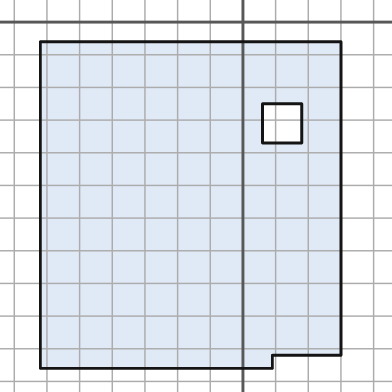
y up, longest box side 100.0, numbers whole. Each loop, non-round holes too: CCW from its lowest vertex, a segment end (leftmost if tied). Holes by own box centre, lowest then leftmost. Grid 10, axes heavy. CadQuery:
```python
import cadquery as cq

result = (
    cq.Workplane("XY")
    .moveTo(-62.0, -106.0)
    .lineTo(9.0, -106.0)
    .lineTo(9.0, -102.0)
    .lineTo(30.0, -102.0)
    .lineTo(30.0, -6.0)
    .lineTo(-62.0, -6.0)
    .close()
    .moveTo(6.0, -37.0)
    .lineTo(18.0, -37.0)
    .lineTo(18.0, -25.0)
    .lineTo(6.0, -25.0)
    .close()
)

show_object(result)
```